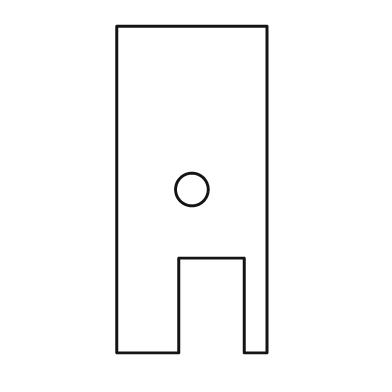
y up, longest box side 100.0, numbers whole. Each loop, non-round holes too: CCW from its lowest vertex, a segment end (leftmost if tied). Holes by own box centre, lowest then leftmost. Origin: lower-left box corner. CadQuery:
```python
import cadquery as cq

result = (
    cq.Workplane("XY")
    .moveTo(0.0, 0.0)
    .lineTo(19.0, 0.0)
    .lineTo(19.0, 29.0)
    .lineTo(39.0, 29.0)
    .lineTo(39.0, 0.0)
    .lineTo(46.0, 0.0)
    .lineTo(46.0, 100.0)
    .lineTo(0.0, 100.0)
    .close()
    .moveTo(23.0, 50.0)
    .circle(5.0)
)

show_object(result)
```